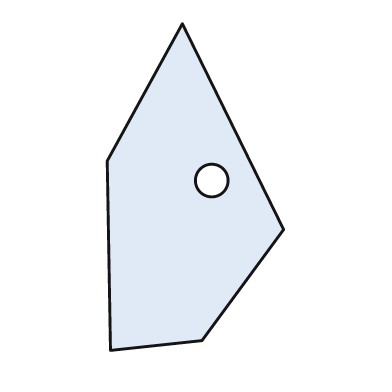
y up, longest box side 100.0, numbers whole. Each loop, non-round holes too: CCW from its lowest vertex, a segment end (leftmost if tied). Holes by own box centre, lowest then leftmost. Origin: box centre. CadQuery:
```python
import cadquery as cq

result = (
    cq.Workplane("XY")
    .moveTo(-26.0, -50.0)
    .lineTo(2.0, -47.0)
    .lineTo(27.0, -13.0)
    .lineTo(-4.0, 50.0)
    .lineTo(-27.0, 8.0)
    .close()
    .moveTo(5.0, 2.0)
    .circle(5.0)
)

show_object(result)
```